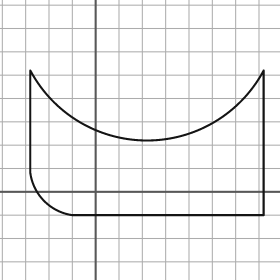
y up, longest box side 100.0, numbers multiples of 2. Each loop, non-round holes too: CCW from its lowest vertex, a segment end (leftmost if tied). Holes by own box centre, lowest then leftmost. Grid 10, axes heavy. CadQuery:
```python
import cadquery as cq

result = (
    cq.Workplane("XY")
    .moveTo(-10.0, -10.0)
    .lineTo(72.0, -10.0)
    .lineTo(72.0, 52.0)
    .threePointArc((22.0, 22.0), (-28.0, 52.0))
    .lineTo(-28.0, 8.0)
    .threePointArc((-22.0, -4.0), (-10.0, -10.0))
    .close()
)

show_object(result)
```